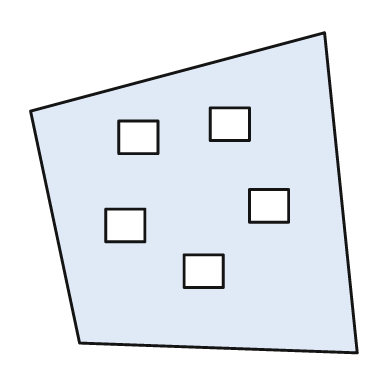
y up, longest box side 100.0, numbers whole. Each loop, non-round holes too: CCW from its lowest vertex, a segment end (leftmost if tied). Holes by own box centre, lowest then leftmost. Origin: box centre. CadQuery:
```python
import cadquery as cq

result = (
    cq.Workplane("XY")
    .moveTo(50.0, -49.0)
    .lineTo(40.0, 49.0)
    .lineTo(-50.0, 25.0)
    .lineTo(-35.0, -46.0)
    .close()
    .moveTo(-3.0, -29.0)
    .lineTo(9.0, -29.0)
    .lineTo(9.0, -19.0)
    .lineTo(-3.0, -19.0)
    .close()
    .moveTo(-27.0, -15.0)
    .lineTo(-15.0, -15.0)
    .lineTo(-15.0, -5.0)
    .lineTo(-27.0, -5.0)
    .close()
    .moveTo(17.0, -9.0)
    .lineTo(29.0, -9.0)
    .lineTo(29.0, 1.0)
    .lineTo(17.0, 1.0)
    .close()
    .moveTo(-23.0, 12.0)
    .lineTo(-11.0, 12.0)
    .lineTo(-11.0, 22.0)
    .lineTo(-23.0, 22.0)
    .close()
    .moveTo(5.0, 16.0)
    .lineTo(17.0, 16.0)
    .lineTo(17.0, 26.0)
    .lineTo(5.0, 26.0)
    .close()
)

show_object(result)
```